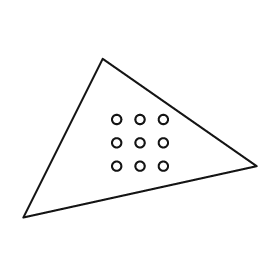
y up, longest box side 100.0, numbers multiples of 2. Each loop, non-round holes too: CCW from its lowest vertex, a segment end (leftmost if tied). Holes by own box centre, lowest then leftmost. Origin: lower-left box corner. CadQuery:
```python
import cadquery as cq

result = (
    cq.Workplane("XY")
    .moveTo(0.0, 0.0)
    .lineTo(100.0, 22.0)
    .lineTo(34.0, 68.0)
    .close()
    .moveTo(40.0, 22.0)
    .circle(2.0)
    .moveTo(50.0, 22.0)
    .circle(2.0)
    .moveTo(60.0, 22.0)
    .circle(2.0)
    .moveTo(40.0, 32.0)
    .circle(2.0)
    .moveTo(50.0, 32.0)
    .circle(2.0)
    .moveTo(60.0, 32.0)
    .circle(2.0)
    .moveTo(40.0, 42.0)
    .circle(2.0)
    .moveTo(50.0, 42.0)
    .circle(2.0)
    .moveTo(60.0, 42.0)
    .circle(2.0)
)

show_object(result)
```